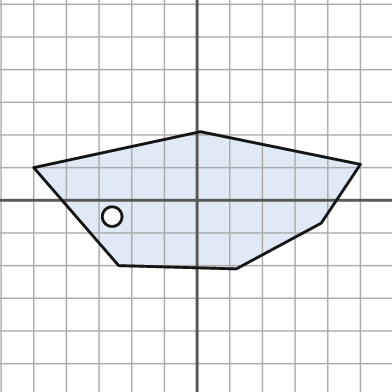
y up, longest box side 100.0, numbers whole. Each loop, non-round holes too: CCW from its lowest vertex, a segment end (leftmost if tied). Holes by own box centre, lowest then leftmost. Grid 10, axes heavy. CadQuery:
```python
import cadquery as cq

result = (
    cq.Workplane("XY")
    .moveTo(12.0, -21.0)
    .lineTo(38.0, -7.0)
    .lineTo(50.0, 11.0)
    .lineTo(1.0, 21.0)
    .lineTo(-50.0, 10.0)
    .lineTo(-24.0, -20.0)
    .close()
    .moveTo(-26.0, -5.0)
    .circle(3.0)
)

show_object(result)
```